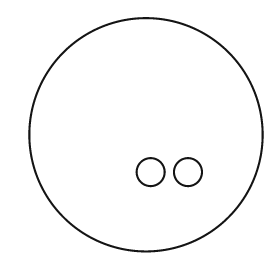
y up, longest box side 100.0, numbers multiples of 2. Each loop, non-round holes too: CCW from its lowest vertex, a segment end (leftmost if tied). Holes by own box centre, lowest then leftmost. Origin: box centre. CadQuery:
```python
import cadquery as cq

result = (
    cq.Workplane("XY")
    .moveTo(0.0, 0.0)
    .circle(50.0)
    .moveTo(2.0, -16.0)
    .circle(6.0)
    .moveTo(18.0, -16.0)
    .circle(6.0)
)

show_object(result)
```